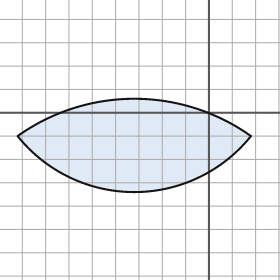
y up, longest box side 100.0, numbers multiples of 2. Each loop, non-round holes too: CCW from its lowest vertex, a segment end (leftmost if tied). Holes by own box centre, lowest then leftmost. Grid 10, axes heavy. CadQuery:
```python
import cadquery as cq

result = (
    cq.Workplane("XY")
    .moveTo(-82.0, -10.0)
    .threePointArc((-32.0, -34.0), (18.0, -10.0))
    .threePointArc((-32.0, 6.0), (-82.0, -10.0))
    .close()
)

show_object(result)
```